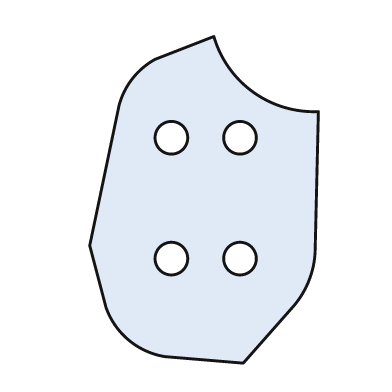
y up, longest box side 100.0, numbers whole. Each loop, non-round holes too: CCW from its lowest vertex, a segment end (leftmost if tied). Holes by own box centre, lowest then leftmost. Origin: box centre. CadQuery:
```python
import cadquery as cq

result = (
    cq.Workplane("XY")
    .moveTo(12.0, -50.0)
    .lineTo(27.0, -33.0)
    .threePointArc((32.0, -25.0), (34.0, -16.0))
    .lineTo(35.0, 27.0)
    .threePointArc((15.0, 33.0), (3.0, 50.0))
    .lineTo(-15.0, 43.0)
    .threePointArc((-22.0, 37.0), (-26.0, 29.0))
    .lineTo(-35.0, -14.0)
    .lineTo(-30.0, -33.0)
    .threePointArc((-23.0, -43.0), (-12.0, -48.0))
    .close()
    .moveTo(-10.0, -18.0)
    .circle(5.0)
    .moveTo(11.0, -18.0)
    .circle(5.0)
    .moveTo(-10.0, 19.0)
    .circle(5.0)
    .moveTo(11.0, 19.0)
    .circle(5.0)
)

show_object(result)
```